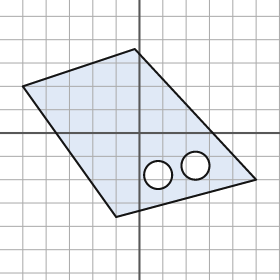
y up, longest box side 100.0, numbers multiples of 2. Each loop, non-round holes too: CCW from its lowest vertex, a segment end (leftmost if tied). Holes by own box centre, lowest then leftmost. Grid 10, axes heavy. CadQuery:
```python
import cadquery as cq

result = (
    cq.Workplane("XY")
    .moveTo(-10.0, -36.0)
    .lineTo(50.0, -20.0)
    .lineTo(-2.0, 36.0)
    .lineTo(-50.0, 20.0)
    .close()
    .moveTo(8.0, -18.0)
    .circle(6.0)
    .moveTo(24.0, -14.0)
    .circle(6.0)
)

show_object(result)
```